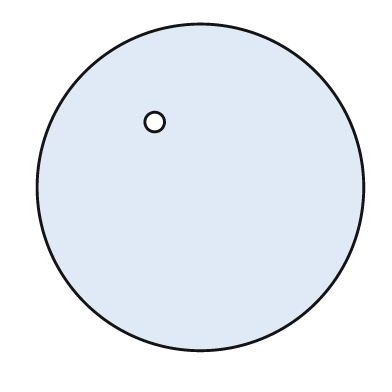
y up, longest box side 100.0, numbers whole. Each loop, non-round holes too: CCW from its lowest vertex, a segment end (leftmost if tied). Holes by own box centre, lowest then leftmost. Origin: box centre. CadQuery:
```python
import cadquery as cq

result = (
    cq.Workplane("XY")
    .moveTo(0.0, 0.0)
    .circle(50.0)
    .moveTo(-14.0, 20.0)
    .circle(3.0)
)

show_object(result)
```